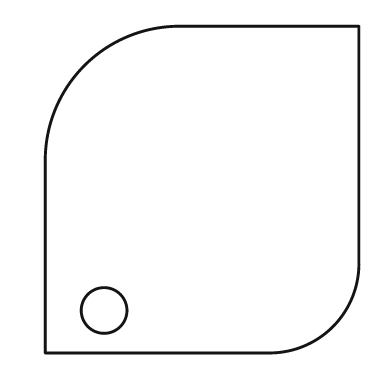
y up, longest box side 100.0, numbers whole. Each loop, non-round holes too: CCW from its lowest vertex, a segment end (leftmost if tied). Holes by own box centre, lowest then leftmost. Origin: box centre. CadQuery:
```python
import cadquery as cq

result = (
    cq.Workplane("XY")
    .moveTo(-48.0, -50.0)
    .lineTo(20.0, -50.0)
    .threePointArc((40.0, -42.0), (48.0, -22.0))
    .lineTo(48.0, 50.0)
    .lineTo(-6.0, 50.0)
    .threePointArc((-36.0, 38.0), (-48.0, 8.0))
    .close()
    .moveTo(-30.0, -37.0)
    .circle(7.0)
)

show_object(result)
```